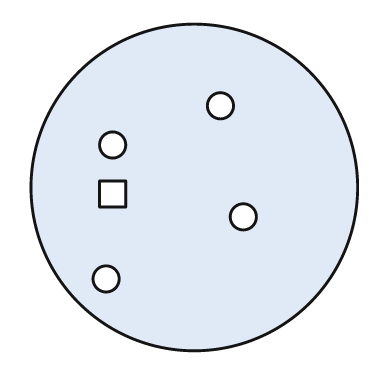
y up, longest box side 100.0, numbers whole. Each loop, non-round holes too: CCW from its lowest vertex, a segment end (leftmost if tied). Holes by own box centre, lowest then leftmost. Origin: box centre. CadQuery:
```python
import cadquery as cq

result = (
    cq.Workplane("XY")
    .moveTo(0.0, 0.0)
    .circle(50.0)
    .moveTo(-27.0, -28.0)
    .circle(4.0)
    .moveTo(15.0, -9.0)
    .circle(4.0)
    .moveTo(-29.0, -6.0)
    .lineTo(-21.0, -6.0)
    .lineTo(-21.0, 2.0)
    .lineTo(-29.0, 2.0)
    .close()
    .moveTo(-25.0, 13.0)
    .circle(4.0)
    .moveTo(8.0, 25.0)
    .circle(4.0)
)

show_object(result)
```